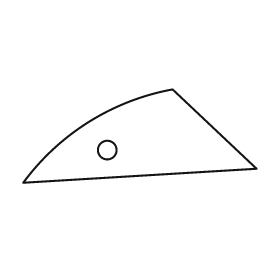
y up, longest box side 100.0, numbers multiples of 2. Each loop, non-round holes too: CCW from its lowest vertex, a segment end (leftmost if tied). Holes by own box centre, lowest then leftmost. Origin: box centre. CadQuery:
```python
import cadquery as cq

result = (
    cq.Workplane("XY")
    .moveTo(-50.0, -20.0)
    .lineTo(50.0, -14.0)
    .lineTo(14.0, 20.0)
    .threePointArc((-22.0, 6.0), (-50.0, -20.0))
    .close()
    .moveTo(-14.0, -6.0)
    .circle(4.0)
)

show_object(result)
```